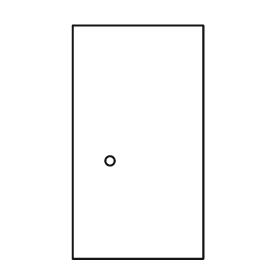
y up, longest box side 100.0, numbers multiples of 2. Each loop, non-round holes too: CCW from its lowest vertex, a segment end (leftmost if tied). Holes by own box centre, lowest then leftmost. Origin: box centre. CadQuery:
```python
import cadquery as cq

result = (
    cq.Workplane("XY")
    .moveTo(-28.0, -50.0)
    .lineTo(28.0, -50.0)
    .lineTo(28.0, 50.0)
    .lineTo(-28.0, 50.0)
    .close()
    .moveTo(-12.0, -8.0)
    .circle(2.0)
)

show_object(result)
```